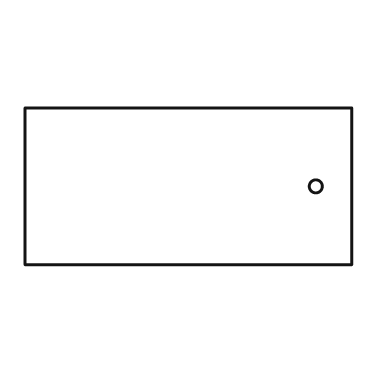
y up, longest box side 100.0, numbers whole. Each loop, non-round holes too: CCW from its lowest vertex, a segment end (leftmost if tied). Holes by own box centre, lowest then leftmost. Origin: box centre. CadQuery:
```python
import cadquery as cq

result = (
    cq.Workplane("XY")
    .moveTo(-50.0, -24.0)
    .lineTo(50.0, -24.0)
    .lineTo(50.0, 24.0)
    .lineTo(-50.0, 24.0)
    .close()
    .moveTo(39.0, 0.0)
    .circle(2.0)
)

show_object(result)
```